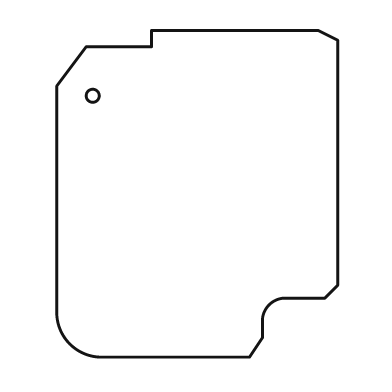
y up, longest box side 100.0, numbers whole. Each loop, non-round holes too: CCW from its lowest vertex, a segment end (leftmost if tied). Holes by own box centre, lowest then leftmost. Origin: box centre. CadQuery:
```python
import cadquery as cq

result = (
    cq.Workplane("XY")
    .moveTo(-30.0, -50.0)
    .lineTo(16.0, -50.0)
    .lineTo(20.0, -44.0)
    .lineTo(20.0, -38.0)
    .threePointArc((22.0, -34.0), (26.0, -32.0))
    .lineTo(39.0, -32.0)
    .lineTo(43.0, -28.0)
    .lineTo(43.0, 47.0)
    .lineTo(37.0, 50.0)
    .lineTo(-14.0, 50.0)
    .lineTo(-14.0, 45.0)
    .lineTo(-34.0, 45.0)
    .lineTo(-43.0, 33.0)
    .lineTo(-43.0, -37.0)
    .threePointArc((-39.0, -46.0), (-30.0, -50.0))
    .close()
    .moveTo(-32.0, 30.0)
    .circle(2.0)
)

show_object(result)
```